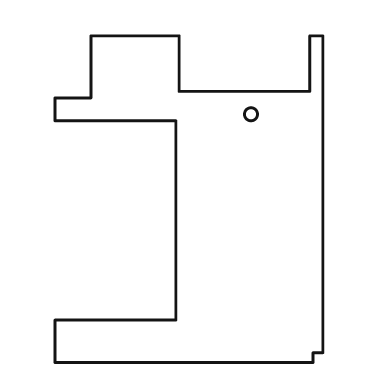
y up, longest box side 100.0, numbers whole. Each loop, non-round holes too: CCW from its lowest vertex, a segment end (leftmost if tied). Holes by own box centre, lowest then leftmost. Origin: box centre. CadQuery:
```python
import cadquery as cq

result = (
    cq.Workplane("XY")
    .moveTo(-41.0, -50.0)
    .lineTo(38.0, -50.0)
    .lineTo(38.0, -47.0)
    .lineTo(41.0, -47.0)
    .lineTo(41.0, 50.0)
    .lineTo(37.0, 50.0)
    .lineTo(37.0, 33.0)
    .lineTo(-3.0, 33.0)
    .lineTo(-3.0, 50.0)
    .lineTo(-30.0, 50.0)
    .lineTo(-30.0, 31.0)
    .lineTo(-41.0, 31.0)
    .lineTo(-41.0, 24.0)
    .lineTo(-4.0, 24.0)
    .lineTo(-4.0, -37.0)
    .lineTo(-41.0, -37.0)
    .close()
    .moveTo(19.0, 26.0)
    .circle(2.0)
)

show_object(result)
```